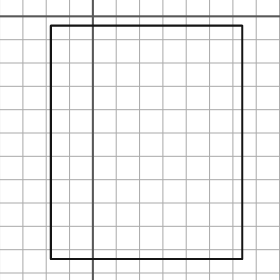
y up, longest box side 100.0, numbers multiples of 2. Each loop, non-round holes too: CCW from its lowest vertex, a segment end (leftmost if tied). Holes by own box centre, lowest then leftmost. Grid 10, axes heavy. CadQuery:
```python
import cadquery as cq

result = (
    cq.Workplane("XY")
    .moveTo(-18.0, -104.0)
    .lineTo(64.0, -104.0)
    .lineTo(64.0, -4.0)
    .lineTo(-18.0, -4.0)
    .close()
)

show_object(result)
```